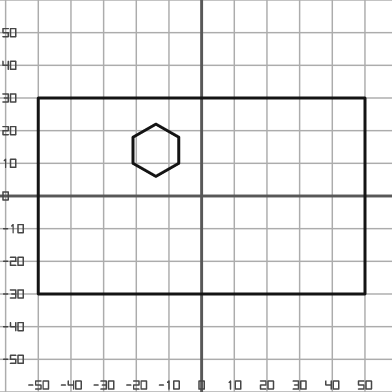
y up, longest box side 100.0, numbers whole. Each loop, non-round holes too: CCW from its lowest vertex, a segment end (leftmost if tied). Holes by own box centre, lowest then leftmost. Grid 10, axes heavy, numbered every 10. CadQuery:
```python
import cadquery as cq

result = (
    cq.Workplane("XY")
    .moveTo(-50.0, -30.0)
    .lineTo(50.0, -30.0)
    .lineTo(50.0, 30.0)
    .lineTo(-50.0, 30.0)
    .close()
    .moveTo(-14.0, 6.0)
    .lineTo(-7.0, 10.0)
    .lineTo(-7.0, 18.0)
    .lineTo(-14.0, 22.0)
    .lineTo(-21.0, 18.0)
    .lineTo(-21.0, 10.0)
    .close()
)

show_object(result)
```